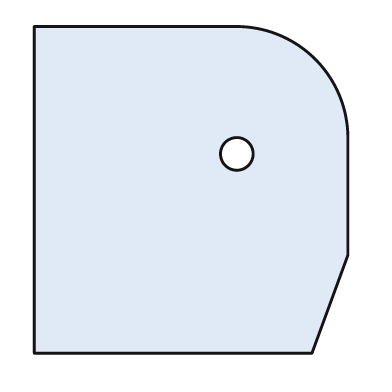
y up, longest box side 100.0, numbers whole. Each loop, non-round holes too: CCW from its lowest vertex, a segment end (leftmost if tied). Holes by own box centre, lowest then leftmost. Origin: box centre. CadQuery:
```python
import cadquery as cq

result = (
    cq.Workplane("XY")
    .moveTo(-48.0, -50.0)
    .lineTo(37.0, -50.0)
    .lineTo(48.0, -20.0)
    .lineTo(48.0, 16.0)
    .threePointArc((38.0, 40.0), (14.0, 50.0))
    .lineTo(-48.0, 50.0)
    .close()
    .moveTo(14.0, 11.0)
    .circle(5.0)
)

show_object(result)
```